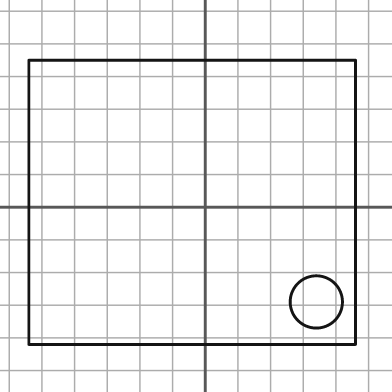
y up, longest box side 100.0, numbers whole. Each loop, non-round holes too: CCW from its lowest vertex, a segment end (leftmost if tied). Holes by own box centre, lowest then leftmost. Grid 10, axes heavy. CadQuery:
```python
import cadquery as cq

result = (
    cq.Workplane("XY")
    .moveTo(-54.0, -42.0)
    .lineTo(46.0, -42.0)
    .lineTo(46.0, 45.0)
    .lineTo(-54.0, 45.0)
    .close()
    .moveTo(34.0, -29.0)
    .circle(8.0)
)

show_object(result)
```